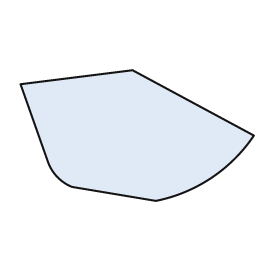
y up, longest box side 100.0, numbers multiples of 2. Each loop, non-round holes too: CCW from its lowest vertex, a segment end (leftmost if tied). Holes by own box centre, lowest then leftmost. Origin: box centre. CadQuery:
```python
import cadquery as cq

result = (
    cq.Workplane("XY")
    .moveTo(8.0, -28.0)
    .threePointArc((32.0, -18.0), (50.0, 0.0))
    .lineTo(-2.0, 28.0)
    .lineTo(-50.0, 22.0)
    .lineTo(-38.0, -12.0)
    .threePointArc((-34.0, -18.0), (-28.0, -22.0))
    .close()
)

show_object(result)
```